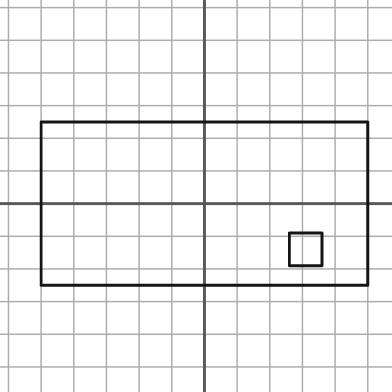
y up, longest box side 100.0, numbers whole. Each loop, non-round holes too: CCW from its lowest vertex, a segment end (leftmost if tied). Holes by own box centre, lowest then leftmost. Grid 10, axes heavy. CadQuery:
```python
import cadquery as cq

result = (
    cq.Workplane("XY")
    .moveTo(-50.0, -25.0)
    .lineTo(50.0, -25.0)
    .lineTo(50.0, 25.0)
    .lineTo(-50.0, 25.0)
    .close()
    .moveTo(26.0, -19.0)
    .lineTo(36.0, -19.0)
    .lineTo(36.0, -9.0)
    .lineTo(26.0, -9.0)
    .close()
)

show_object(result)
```